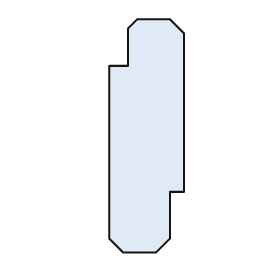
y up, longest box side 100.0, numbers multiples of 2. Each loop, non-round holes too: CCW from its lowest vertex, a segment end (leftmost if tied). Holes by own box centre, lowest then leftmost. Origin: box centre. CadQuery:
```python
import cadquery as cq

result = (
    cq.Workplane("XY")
    .moveTo(-10.0, -50.0)
    .lineTo(4.0, -50.0)
    .lineTo(10.0, -44.0)
    .lineTo(10.0, -24.0)
    .lineTo(16.0, -24.0)
    .lineTo(16.0, 44.0)
    .lineTo(10.0, 50.0)
    .lineTo(-4.0, 50.0)
    .lineTo(-8.0, 46.0)
    .lineTo(-8.0, 30.0)
    .lineTo(-16.0, 30.0)
    .lineTo(-16.0, -44.0)
    .close()
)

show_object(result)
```